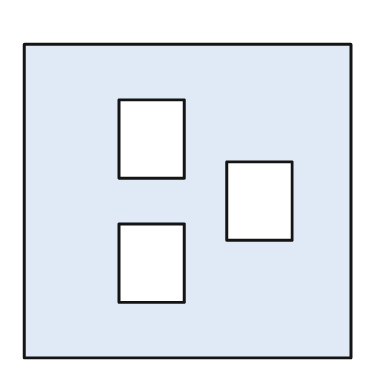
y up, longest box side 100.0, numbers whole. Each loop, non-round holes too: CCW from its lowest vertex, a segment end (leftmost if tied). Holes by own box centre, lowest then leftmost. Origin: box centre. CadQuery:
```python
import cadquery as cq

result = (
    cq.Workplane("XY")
    .moveTo(-50.0, -48.0)
    .lineTo(50.0, -48.0)
    .lineTo(50.0, 48.0)
    .lineTo(-50.0, 48.0)
    .close()
    .moveTo(-21.0, -31.0)
    .lineTo(-1.0, -31.0)
    .lineTo(-1.0, -7.0)
    .lineTo(-21.0, -7.0)
    .close()
    .moveTo(12.0, -12.0)
    .lineTo(32.0, -12.0)
    .lineTo(32.0, 12.0)
    .lineTo(12.0, 12.0)
    .close()
    .moveTo(-21.0, 7.0)
    .lineTo(-1.0, 7.0)
    .lineTo(-1.0, 31.0)
    .lineTo(-21.0, 31.0)
    .close()
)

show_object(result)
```